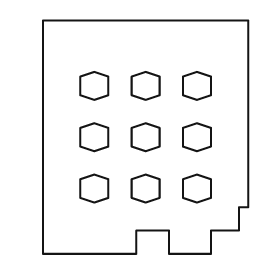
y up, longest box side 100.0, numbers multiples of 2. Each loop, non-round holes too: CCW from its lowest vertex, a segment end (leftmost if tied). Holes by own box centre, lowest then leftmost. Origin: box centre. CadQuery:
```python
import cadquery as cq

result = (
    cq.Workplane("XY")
    .moveTo(-44.0, -50.0)
    .lineTo(-4.0, -50.0)
    .lineTo(-4.0, -40.0)
    .lineTo(10.0, -40.0)
    .lineTo(10.0, -50.0)
    .lineTo(28.0, -50.0)
    .lineTo(28.0, -40.0)
    .lineTo(40.0, -40.0)
    .lineTo(40.0, -30.0)
    .lineTo(44.0, -30.0)
    .lineTo(44.0, 50.0)
    .lineTo(-44.0, 50.0)
    .close()
    .moveTo(-22.0, -28.0)
    .lineTo(-16.0, -26.0)
    .lineTo(-16.0, -18.0)
    .lineTo(-22.0, -16.0)
    .lineTo(-28.0, -18.0)
    .lineTo(-28.0, -26.0)
    .close()
    .moveTo(0.0, -28.0)
    .lineTo(6.0, -26.0)
    .lineTo(6.0, -18.0)
    .lineTo(0.0, -16.0)
    .lineTo(-6.0, -18.0)
    .lineTo(-6.0, -26.0)
    .close()
    .moveTo(22.0, -28.0)
    .lineTo(28.0, -26.0)
    .lineTo(28.0, -18.0)
    .lineTo(22.0, -16.0)
    .lineTo(16.0, -18.0)
    .lineTo(16.0, -26.0)
    .close()
    .moveTo(-22.0, -6.0)
    .lineTo(-16.0, -4.0)
    .lineTo(-16.0, 4.0)
    .lineTo(-22.0, 6.0)
    .lineTo(-28.0, 4.0)
    .lineTo(-28.0, -4.0)
    .close()
    .moveTo(0.0, -6.0)
    .lineTo(6.0, -4.0)
    .lineTo(6.0, 4.0)
    .lineTo(0.0, 6.0)
    .lineTo(-6.0, 4.0)
    .lineTo(-6.0, -4.0)
    .close()
    .moveTo(22.0, -6.0)
    .lineTo(28.0, -4.0)
    .lineTo(28.0, 4.0)
    .lineTo(22.0, 6.0)
    .lineTo(16.0, 4.0)
    .lineTo(16.0, -4.0)
    .close()
    .moveTo(-22.0, 16.0)
    .lineTo(-16.0, 18.0)
    .lineTo(-16.0, 26.0)
    .lineTo(-22.0, 28.0)
    .lineTo(-28.0, 26.0)
    .lineTo(-28.0, 18.0)
    .close()
    .moveTo(0.0, 16.0)
    .lineTo(6.0, 18.0)
    .lineTo(6.0, 26.0)
    .lineTo(0.0, 28.0)
    .lineTo(-6.0, 26.0)
    .lineTo(-6.0, 18.0)
    .close()
    .moveTo(22.0, 16.0)
    .lineTo(28.0, 18.0)
    .lineTo(28.0, 26.0)
    .lineTo(22.0, 28.0)
    .lineTo(16.0, 26.0)
    .lineTo(16.0, 18.0)
    .close()
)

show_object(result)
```